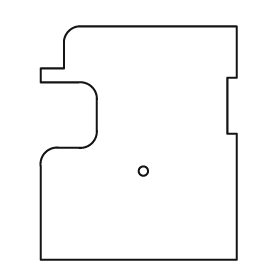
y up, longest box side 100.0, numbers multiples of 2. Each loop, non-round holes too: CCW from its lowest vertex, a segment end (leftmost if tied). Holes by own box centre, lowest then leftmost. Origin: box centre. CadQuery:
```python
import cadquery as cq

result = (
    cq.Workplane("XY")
    .moveTo(-42.0, -50.0)
    .lineTo(42.0, -50.0)
    .lineTo(42.0, 4.0)
    .lineTo(38.0, 4.0)
    .lineTo(38.0, 28.0)
    .lineTo(42.0, 28.0)
    .lineTo(42.0, 50.0)
    .lineTo(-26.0, 50.0)
    .threePointArc((-30.0, 48.0), (-32.0, 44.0))
    .lineTo(-32.0, 32.0)
    .lineTo(-42.0, 32.0)
    .lineTo(-42.0, 26.0)
    .lineTo(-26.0, 26.0)
    .threePointArc((-20.0, 24.0), (-18.0, 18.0))
    .lineTo(-18.0, 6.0)
    .threePointArc((-20.0, 0.0), (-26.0, -2.0))
    .lineTo(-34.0, -2.0)
    .threePointArc((-40.0, -4.0), (-42.0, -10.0))
    .close()
    .moveTo(2.0, -12.0)
    .circle(2.0)
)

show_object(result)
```